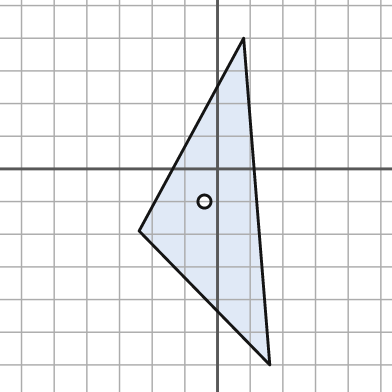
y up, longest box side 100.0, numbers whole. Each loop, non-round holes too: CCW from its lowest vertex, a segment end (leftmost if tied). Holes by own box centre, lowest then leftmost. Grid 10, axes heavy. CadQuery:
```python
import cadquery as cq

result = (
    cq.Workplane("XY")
    .moveTo(16.0, -60.0)
    .lineTo(8.0, 40.0)
    .lineTo(-24.0, -19.0)
    .close()
    .moveTo(-4.0, -10.0)
    .circle(2.0)
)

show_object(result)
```